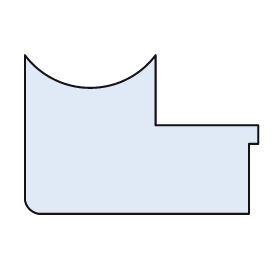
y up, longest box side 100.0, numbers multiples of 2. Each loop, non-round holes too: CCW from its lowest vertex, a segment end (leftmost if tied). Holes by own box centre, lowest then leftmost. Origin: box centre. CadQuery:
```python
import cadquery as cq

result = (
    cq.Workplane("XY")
    .moveTo(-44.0, -34.0)
    .lineTo(46.0, -34.0)
    .lineTo(46.0, -4.0)
    .lineTo(50.0, -4.0)
    .lineTo(50.0, 4.0)
    .lineTo(6.0, 4.0)
    .lineTo(6.0, 34.0)
    .threePointArc((-22.0, 20.0), (-50.0, 34.0))
    .lineTo(-50.0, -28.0)
    .threePointArc((-48.0, -32.0), (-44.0, -34.0))
    .close()
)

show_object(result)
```